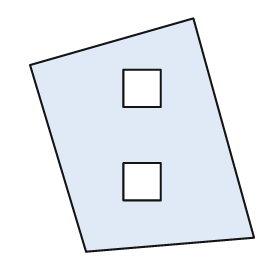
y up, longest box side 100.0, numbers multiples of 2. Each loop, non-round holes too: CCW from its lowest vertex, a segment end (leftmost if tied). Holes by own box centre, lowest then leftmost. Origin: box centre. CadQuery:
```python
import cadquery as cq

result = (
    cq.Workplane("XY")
    .moveTo(-24.0, -50.0)
    .lineTo(48.0, -44.0)
    .lineTo(22.0, 50.0)
    .lineTo(-48.0, 30.0)
    .close()
    .moveTo(-8.0, -28.0)
    .lineTo(8.0, -28.0)
    .lineTo(8.0, -12.0)
    .lineTo(-8.0, -12.0)
    .close()
    .moveTo(-8.0, 12.0)
    .lineTo(8.0, 12.0)
    .lineTo(8.0, 28.0)
    .lineTo(-8.0, 28.0)
    .close()
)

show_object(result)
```